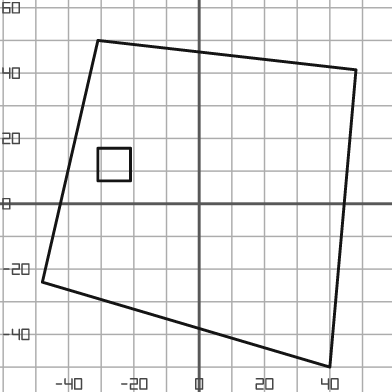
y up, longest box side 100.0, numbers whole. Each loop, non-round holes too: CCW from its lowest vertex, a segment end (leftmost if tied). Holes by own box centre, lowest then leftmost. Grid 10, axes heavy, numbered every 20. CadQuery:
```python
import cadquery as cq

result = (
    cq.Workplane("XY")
    .moveTo(40.0, -50.0)
    .lineTo(48.0, 41.0)
    .lineTo(-31.0, 50.0)
    .lineTo(-48.0, -24.0)
    .close()
    .moveTo(-31.0, 7.0)
    .lineTo(-21.0, 7.0)
    .lineTo(-21.0, 17.0)
    .lineTo(-31.0, 17.0)
    .close()
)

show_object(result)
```